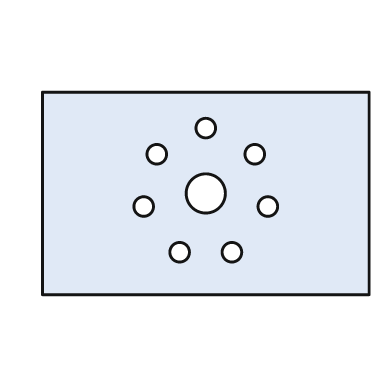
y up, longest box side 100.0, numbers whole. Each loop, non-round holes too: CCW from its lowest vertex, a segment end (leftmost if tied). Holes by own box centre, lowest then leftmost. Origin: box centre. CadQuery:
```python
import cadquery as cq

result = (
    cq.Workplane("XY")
    .moveTo(-50.0, -31.0)
    .lineTo(50.0, -31.0)
    .lineTo(50.0, 31.0)
    .lineTo(-50.0, 31.0)
    .close()
    .moveTo(-8.0, -18.0)
    .circle(3.0)
    .moveTo(8.0, -18.0)
    .circle(3.0)
    .moveTo(-19.0, -4.0)
    .circle(3.0)
    .moveTo(19.0, -4.0)
    .circle(3.0)
    .moveTo(0.0, 0.0)
    .circle(6.0)
    .moveTo(-15.0, 12.0)
    .circle(3.0)
    .moveTo(15.0, 12.0)
    .circle(3.0)
    .moveTo(0.0, 20.0)
    .circle(3.0)
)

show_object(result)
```